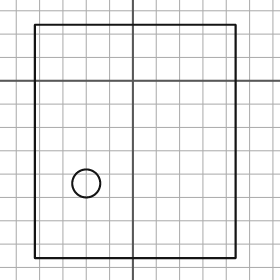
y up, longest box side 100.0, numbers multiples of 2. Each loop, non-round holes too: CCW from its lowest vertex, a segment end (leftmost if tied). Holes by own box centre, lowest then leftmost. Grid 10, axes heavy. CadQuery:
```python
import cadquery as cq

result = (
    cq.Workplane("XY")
    .moveTo(-42.0, -76.0)
    .lineTo(44.0, -76.0)
    .lineTo(44.0, 24.0)
    .lineTo(-42.0, 24.0)
    .close()
    .moveTo(-20.0, -44.0)
    .circle(6.0)
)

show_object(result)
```